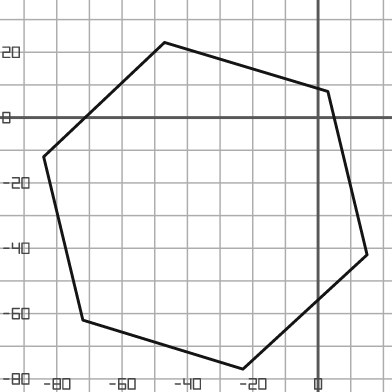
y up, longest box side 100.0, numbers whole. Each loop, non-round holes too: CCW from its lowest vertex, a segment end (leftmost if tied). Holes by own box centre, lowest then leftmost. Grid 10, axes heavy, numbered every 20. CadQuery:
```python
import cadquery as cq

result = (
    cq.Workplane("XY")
    .moveTo(-23.0, -77.0)
    .lineTo(15.0, -42.0)
    .lineTo(3.0, 8.0)
    .lineTo(-47.0, 23.0)
    .lineTo(-84.0, -12.0)
    .lineTo(-72.0, -62.0)
    .close()
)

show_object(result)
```